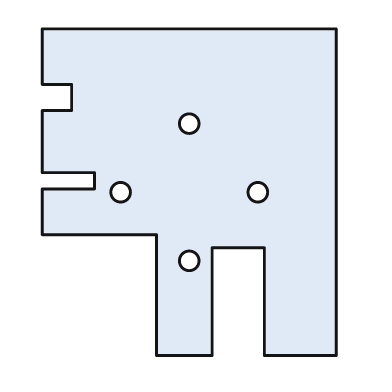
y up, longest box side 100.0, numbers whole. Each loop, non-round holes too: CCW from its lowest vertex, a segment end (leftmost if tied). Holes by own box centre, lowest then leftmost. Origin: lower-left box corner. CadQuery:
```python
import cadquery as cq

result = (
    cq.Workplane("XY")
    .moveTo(35.0, 0.0)
    .lineTo(52.0, 0.0)
    .lineTo(52.0, 33.0)
    .lineTo(68.0, 33.0)
    .lineTo(68.0, 0.0)
    .lineTo(90.0, 0.0)
    .lineTo(90.0, 100.0)
    .lineTo(0.0, 100.0)
    .lineTo(0.0, 83.0)
    .lineTo(9.0, 83.0)
    .lineTo(9.0, 75.0)
    .lineTo(0.0, 75.0)
    .lineTo(0.0, 56.0)
    .lineTo(16.0, 56.0)
    .lineTo(16.0, 51.0)
    .lineTo(0.0, 51.0)
    .lineTo(0.0, 37.0)
    .lineTo(35.0, 37.0)
    .close()
    .moveTo(45.0, 29.0)
    .circle(3.0)
    .moveTo(24.0, 50.0)
    .circle(3.0)
    .moveTo(66.0, 50.0)
    .circle(3.0)
    .moveTo(45.0, 71.0)
    .circle(3.0)
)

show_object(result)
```